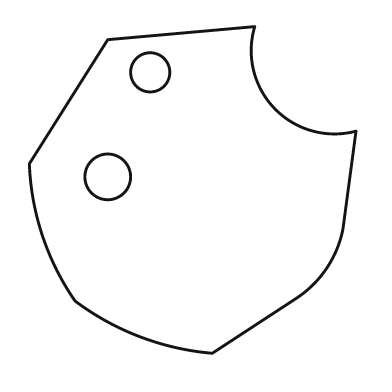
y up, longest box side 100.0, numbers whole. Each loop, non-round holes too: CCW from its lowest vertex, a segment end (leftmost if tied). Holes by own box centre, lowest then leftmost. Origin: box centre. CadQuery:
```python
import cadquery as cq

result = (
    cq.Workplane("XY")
    .moveTo(6.0, -50.0)
    .lineTo(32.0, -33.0)
    .threePointArc((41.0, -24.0), (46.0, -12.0))
    .lineTo(50.0, 18.0)
    .threePointArc((25.0, 25.0), (19.0, 50.0))
    .lineTo(-26.0, 46.0)
    .lineTo(-50.0, 8.0)
    .threePointArc((-46.0, -14.0), (-36.0, -34.0))
    .threePointArc((-16.0, -45.0), (6.0, -50.0))
    .close()
    .moveTo(-26.0, 4.0)
    .circle(7.0)
    .moveTo(-13.0, 36.0)
    .circle(6.0)
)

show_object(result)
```